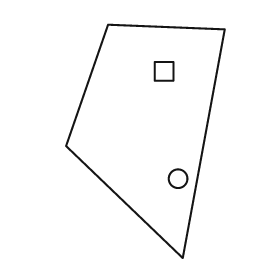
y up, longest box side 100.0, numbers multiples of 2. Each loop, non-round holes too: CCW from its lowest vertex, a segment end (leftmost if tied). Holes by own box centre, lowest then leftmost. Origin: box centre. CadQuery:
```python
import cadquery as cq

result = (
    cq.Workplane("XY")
    .moveTo(16.0, -50.0)
    .lineTo(34.0, 48.0)
    .lineTo(-16.0, 50.0)
    .lineTo(-34.0, -2.0)
    .close()
    .moveTo(14.0, -16.0)
    .circle(4.0)
    .moveTo(4.0, 26.0)
    .lineTo(12.0, 26.0)
    .lineTo(12.0, 34.0)
    .lineTo(4.0, 34.0)
    .close()
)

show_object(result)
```